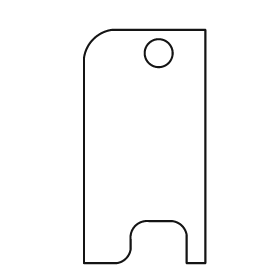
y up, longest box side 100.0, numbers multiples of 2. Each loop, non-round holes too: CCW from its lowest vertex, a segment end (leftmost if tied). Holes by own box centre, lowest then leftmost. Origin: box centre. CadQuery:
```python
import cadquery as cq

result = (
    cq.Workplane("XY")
    .moveTo(-26.0, -50.0)
    .lineTo(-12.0, -50.0)
    .threePointArc((-8.0, -48.0), (-6.0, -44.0))
    .lineTo(-6.0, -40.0)
    .threePointArc((-4.0, -34.0), (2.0, -32.0))
    .lineTo(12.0, -32.0)
    .threePointArc((16.0, -34.0), (18.0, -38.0))
    .lineTo(18.0, -50.0)
    .lineTo(26.0, -50.0)
    .lineTo(26.0, 50.0)
    .lineTo(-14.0, 50.0)
    .threePointArc((-22.0, 46.0), (-26.0, 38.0))
    .close()
    .moveTo(6.0, 40.0)
    .circle(6.0)
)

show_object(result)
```